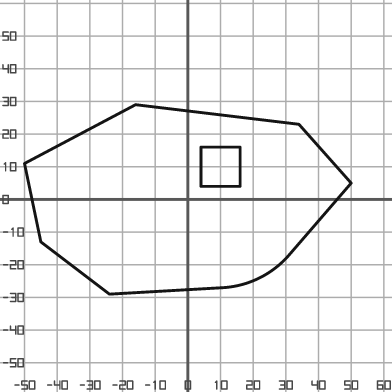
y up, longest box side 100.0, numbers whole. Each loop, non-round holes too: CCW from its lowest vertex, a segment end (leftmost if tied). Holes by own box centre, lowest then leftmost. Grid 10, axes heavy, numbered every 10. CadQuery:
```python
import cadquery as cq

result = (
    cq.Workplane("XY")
    .moveTo(-24.0, -29.0)
    .lineTo(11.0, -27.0)
    .threePointArc((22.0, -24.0), (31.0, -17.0))
    .lineTo(50.0, 5.0)
    .lineTo(34.0, 23.0)
    .lineTo(-16.0, 29.0)
    .lineTo(-50.0, 11.0)
    .lineTo(-45.0, -13.0)
    .close()
    .moveTo(4.0, 4.0)
    .lineTo(16.0, 4.0)
    .lineTo(16.0, 16.0)
    .lineTo(4.0, 16.0)
    .close()
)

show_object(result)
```